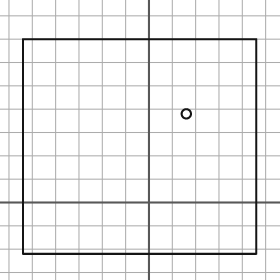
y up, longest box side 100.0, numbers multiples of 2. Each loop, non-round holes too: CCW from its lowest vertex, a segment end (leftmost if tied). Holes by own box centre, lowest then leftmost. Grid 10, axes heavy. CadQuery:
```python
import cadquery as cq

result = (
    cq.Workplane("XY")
    .moveTo(-54.0, -22.0)
    .lineTo(46.0, -22.0)
    .lineTo(46.0, 70.0)
    .lineTo(-54.0, 70.0)
    .close()
    .moveTo(16.0, 38.0)
    .circle(2.0)
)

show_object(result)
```